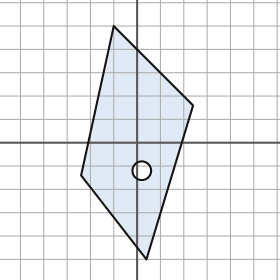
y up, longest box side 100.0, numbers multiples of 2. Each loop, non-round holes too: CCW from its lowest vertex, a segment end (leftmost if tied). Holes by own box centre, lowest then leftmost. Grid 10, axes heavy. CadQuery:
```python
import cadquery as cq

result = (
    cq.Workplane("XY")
    .moveTo(4.0, -50.0)
    .lineTo(24.0, 16.0)
    .lineTo(-10.0, 50.0)
    .lineTo(-24.0, -14.0)
    .close()
    .moveTo(2.0, -12.0)
    .circle(4.0)
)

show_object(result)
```